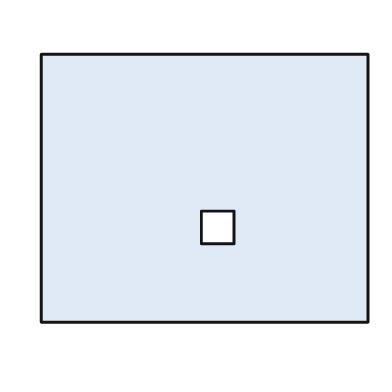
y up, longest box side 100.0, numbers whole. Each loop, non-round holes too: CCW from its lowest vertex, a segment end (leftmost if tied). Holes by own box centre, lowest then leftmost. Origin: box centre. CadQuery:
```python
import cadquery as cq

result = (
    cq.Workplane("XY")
    .moveTo(-50.0, -41.0)
    .lineTo(50.0, -41.0)
    .lineTo(50.0, 41.0)
    .lineTo(-50.0, 41.0)
    .close()
    .moveTo(-1.0, -17.0)
    .lineTo(9.0, -17.0)
    .lineTo(9.0, -7.0)
    .lineTo(-1.0, -7.0)
    .close()
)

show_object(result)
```